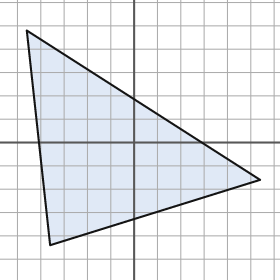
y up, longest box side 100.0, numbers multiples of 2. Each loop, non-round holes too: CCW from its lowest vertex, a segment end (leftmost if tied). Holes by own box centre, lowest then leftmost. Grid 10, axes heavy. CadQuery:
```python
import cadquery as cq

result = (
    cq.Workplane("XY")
    .moveTo(-36.0, -44.0)
    .lineTo(54.0, -16.0)
    .lineTo(-46.0, 48.0)
    .close()
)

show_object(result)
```